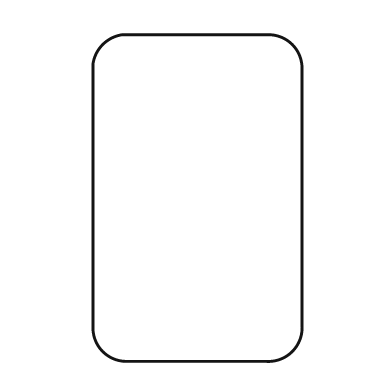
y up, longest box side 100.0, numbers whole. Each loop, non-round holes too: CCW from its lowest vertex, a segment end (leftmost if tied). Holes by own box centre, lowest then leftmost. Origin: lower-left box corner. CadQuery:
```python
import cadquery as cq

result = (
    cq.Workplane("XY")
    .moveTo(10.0, 0.0)
    .lineTo(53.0, 0.0)
    .threePointArc((61.0, 3.0), (64.0, 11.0))
    .lineTo(64.0, 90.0)
    .threePointArc((61.0, 97.0), (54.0, 100.0))
    .lineTo(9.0, 100.0)
    .threePointArc((3.0, 97.0), (0.0, 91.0))
    .lineTo(0.0, 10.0)
    .threePointArc((3.0, 3.0), (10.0, 0.0))
    .close()
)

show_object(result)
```